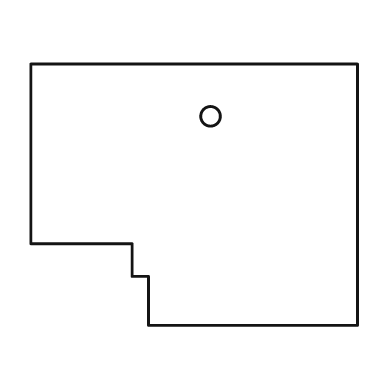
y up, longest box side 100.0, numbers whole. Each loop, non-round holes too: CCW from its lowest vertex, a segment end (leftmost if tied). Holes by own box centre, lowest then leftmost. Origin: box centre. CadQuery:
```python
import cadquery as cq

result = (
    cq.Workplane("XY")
    .moveTo(-14.0, -40.0)
    .lineTo(50.0, -40.0)
    .lineTo(50.0, 40.0)
    .lineTo(-50.0, 40.0)
    .lineTo(-50.0, -15.0)
    .lineTo(-19.0, -15.0)
    .lineTo(-19.0, -25.0)
    .lineTo(-14.0, -25.0)
    .close()
    .moveTo(5.0, 24.0)
    .circle(3.0)
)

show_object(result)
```